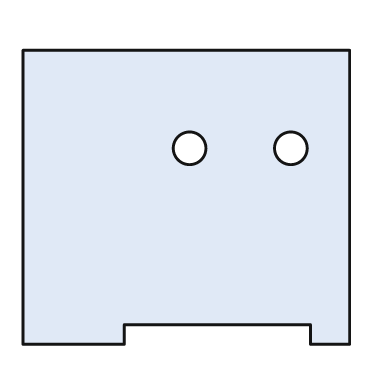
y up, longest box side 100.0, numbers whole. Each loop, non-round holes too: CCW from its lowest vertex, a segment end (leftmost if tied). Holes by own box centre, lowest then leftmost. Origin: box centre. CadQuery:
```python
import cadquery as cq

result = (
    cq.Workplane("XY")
    .moveTo(-50.0, -45.0)
    .lineTo(-19.0, -45.0)
    .lineTo(-19.0, -39.0)
    .lineTo(38.0, -39.0)
    .lineTo(38.0, -45.0)
    .lineTo(50.0, -45.0)
    .lineTo(50.0, 45.0)
    .lineTo(-50.0, 45.0)
    .close()
    .moveTo(1.0, 15.0)
    .circle(5.0)
    .moveTo(32.0, 15.0)
    .circle(5.0)
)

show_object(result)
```